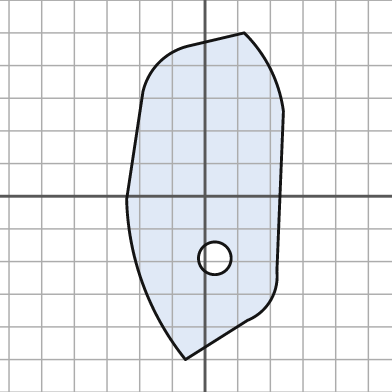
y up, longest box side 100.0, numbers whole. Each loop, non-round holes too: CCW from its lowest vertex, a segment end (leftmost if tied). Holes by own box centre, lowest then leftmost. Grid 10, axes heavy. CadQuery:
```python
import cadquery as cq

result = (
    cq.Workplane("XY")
    .moveTo(-6.0, -50.0)
    .lineTo(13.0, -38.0)
    .threePointArc((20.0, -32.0), (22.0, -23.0))
    .lineTo(24.0, 26.0)
    .threePointArc((20.0, 39.0), (12.0, 50.0))
    .lineTo(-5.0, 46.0)
    .threePointArc((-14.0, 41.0), (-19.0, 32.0))
    .lineTo(-24.0, -1.0)
    .threePointArc((-19.0, -27.0), (-6.0, -50.0))
    .close()
    .moveTo(3.0, -19.0)
    .circle(5.0)
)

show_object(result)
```